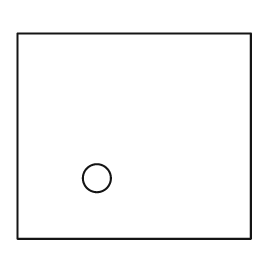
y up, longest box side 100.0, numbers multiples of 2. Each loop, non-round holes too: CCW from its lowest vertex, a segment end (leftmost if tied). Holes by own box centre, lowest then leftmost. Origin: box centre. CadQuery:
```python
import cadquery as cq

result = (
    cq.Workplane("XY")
    .moveTo(-50.0, -44.0)
    .lineTo(50.0, -44.0)
    .lineTo(50.0, 44.0)
    .lineTo(-50.0, 44.0)
    .close()
    .moveTo(-16.0, -18.0)
    .circle(6.0)
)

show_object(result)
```